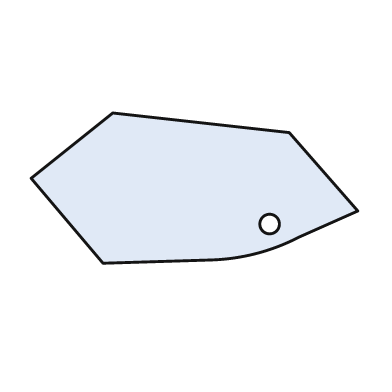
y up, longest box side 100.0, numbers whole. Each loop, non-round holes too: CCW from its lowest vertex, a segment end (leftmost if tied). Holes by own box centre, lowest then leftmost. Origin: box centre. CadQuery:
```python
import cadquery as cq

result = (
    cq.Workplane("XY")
    .moveTo(-28.0, -23.0)
    .lineTo(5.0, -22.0)
    .threePointArc((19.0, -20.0), (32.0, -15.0))
    .lineTo(50.0, -7.0)
    .lineTo(29.0, 17.0)
    .lineTo(-25.0, 23.0)
    .lineTo(-50.0, 3.0)
    .close()
    .moveTo(23.0, -11.0)
    .circle(3.0)
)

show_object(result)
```